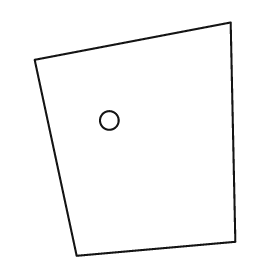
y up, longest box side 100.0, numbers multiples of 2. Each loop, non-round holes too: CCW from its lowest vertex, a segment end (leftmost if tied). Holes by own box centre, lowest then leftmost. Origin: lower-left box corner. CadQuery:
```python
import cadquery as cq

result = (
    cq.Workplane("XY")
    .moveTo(18.0, 0.0)
    .lineTo(86.0, 6.0)
    .lineTo(84.0, 100.0)
    .lineTo(0.0, 84.0)
    .close()
    .moveTo(32.0, 58.0)
    .circle(4.0)
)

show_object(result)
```